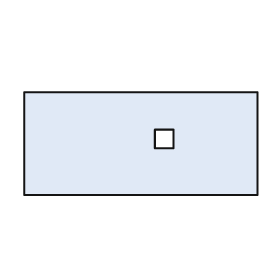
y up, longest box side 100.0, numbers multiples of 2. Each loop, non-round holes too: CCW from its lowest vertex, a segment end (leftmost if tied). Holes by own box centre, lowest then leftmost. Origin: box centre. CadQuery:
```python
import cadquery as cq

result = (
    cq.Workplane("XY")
    .moveTo(-50.0, -22.0)
    .lineTo(50.0, -22.0)
    .lineTo(50.0, 22.0)
    .lineTo(-50.0, 22.0)
    .close()
    .moveTo(6.0, -2.0)
    .lineTo(14.0, -2.0)
    .lineTo(14.0, 6.0)
    .lineTo(6.0, 6.0)
    .close()
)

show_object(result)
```